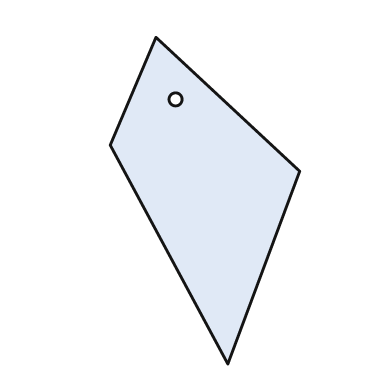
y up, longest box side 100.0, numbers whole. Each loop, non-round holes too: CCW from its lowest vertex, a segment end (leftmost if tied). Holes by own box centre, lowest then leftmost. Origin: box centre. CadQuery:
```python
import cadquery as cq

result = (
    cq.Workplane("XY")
    .moveTo(7.0, -50.0)
    .lineTo(29.0, 9.0)
    .lineTo(-15.0, 50.0)
    .lineTo(-29.0, 17.0)
    .close()
    .moveTo(-9.0, 31.0)
    .circle(2.0)
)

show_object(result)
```